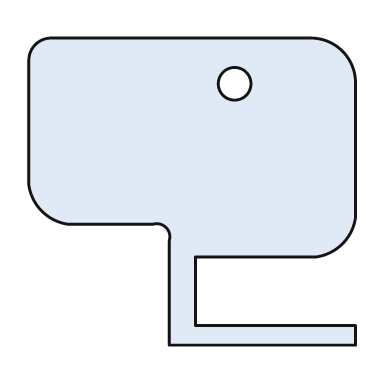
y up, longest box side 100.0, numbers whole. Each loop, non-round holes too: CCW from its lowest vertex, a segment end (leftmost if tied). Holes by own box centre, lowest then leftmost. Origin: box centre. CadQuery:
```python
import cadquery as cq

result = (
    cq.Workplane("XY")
    .moveTo(-7.0, -47.0)
    .lineTo(50.0, -47.0)
    .lineTo(50.0, -41.0)
    .lineTo(1.0, -41.0)
    .lineTo(1.0, -20.0)
    .lineTo(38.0, -20.0)
    .threePointArc((46.0, -16.0), (50.0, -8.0))
    .lineTo(50.0, 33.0)
    .threePointArc((46.0, 43.0), (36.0, 47.0))
    .lineTo(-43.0, 47.0)
    .threePointArc((-48.0, 45.0), (-50.0, 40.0))
    .lineTo(-50.0, 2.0)
    .threePointArc((-46.0, -6.0), (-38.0, -10.0))
    .lineTo(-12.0, -10.0)
    .threePointArc((-8.0, -11.0), (-7.0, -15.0))
    .close()
    .moveTo(13.0, 33.0)
    .circle(5.0)
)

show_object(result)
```